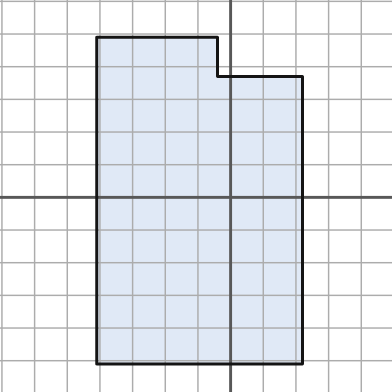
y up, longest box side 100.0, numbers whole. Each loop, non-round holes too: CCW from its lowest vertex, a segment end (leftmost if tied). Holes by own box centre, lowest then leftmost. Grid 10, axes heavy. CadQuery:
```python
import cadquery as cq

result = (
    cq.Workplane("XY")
    .moveTo(-41.0, -51.0)
    .lineTo(22.0, -51.0)
    .lineTo(22.0, 37.0)
    .lineTo(-4.0, 37.0)
    .lineTo(-4.0, 49.0)
    .lineTo(-41.0, 49.0)
    .close()
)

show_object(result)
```